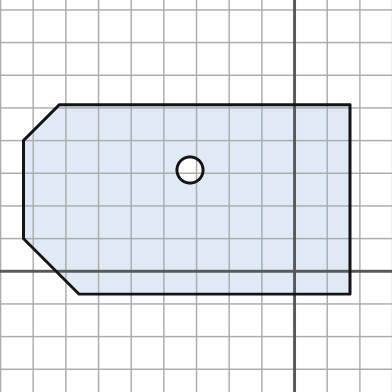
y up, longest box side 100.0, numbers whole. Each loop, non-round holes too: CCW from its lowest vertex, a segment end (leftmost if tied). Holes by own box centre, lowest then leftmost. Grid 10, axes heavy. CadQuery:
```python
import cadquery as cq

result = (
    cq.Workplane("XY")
    .moveTo(-66.0, -7.0)
    .lineTo(17.0, -7.0)
    .lineTo(17.0, 51.0)
    .lineTo(-72.0, 51.0)
    .lineTo(-83.0, 40.0)
    .lineTo(-83.0, 10.0)
    .close()
    .moveTo(-32.0, 31.0)
    .circle(4.0)
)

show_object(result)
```